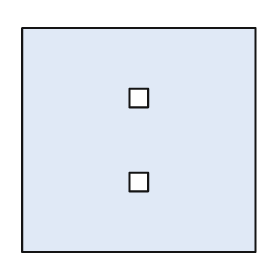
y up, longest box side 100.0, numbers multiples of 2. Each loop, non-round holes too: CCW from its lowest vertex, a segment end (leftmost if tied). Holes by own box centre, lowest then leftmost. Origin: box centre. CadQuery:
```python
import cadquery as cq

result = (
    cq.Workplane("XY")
    .moveTo(-50.0, -48.0)
    .lineTo(50.0, -48.0)
    .lineTo(50.0, 48.0)
    .lineTo(-50.0, 48.0)
    .close()
    .moveTo(-4.0, -22.0)
    .lineTo(4.0, -22.0)
    .lineTo(4.0, -14.0)
    .lineTo(-4.0, -14.0)
    .close()
    .moveTo(-4.0, 14.0)
    .lineTo(4.0, 14.0)
    .lineTo(4.0, 22.0)
    .lineTo(-4.0, 22.0)
    .close()
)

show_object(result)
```